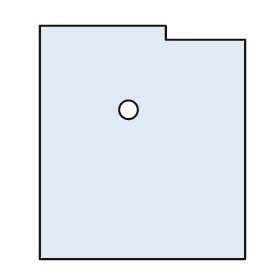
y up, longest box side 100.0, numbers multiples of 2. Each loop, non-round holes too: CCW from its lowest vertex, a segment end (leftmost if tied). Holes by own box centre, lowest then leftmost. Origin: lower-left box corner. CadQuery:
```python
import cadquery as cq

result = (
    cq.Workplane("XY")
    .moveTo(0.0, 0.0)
    .lineTo(88.0, 0.0)
    .lineTo(88.0, 94.0)
    .lineTo(54.0, 94.0)
    .lineTo(54.0, 100.0)
    .lineTo(0.0, 100.0)
    .close()
    .moveTo(38.0, 64.0)
    .circle(4.0)
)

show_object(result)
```